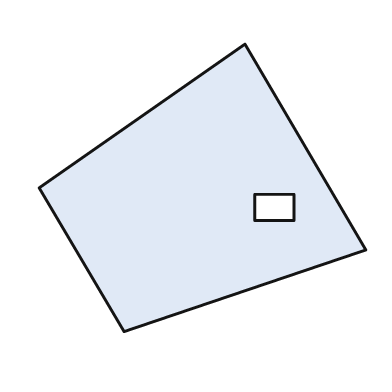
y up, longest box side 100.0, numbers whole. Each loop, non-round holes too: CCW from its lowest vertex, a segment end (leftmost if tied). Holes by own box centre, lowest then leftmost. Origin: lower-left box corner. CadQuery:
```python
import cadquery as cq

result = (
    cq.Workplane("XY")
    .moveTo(26.0, 0.0)
    .lineTo(100.0, 25.0)
    .lineTo(63.0, 88.0)
    .lineTo(0.0, 44.0)
    .close()
    .moveTo(66.0, 34.0)
    .lineTo(78.0, 34.0)
    .lineTo(78.0, 42.0)
    .lineTo(66.0, 42.0)
    .close()
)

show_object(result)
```